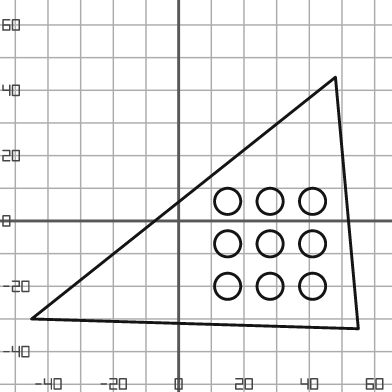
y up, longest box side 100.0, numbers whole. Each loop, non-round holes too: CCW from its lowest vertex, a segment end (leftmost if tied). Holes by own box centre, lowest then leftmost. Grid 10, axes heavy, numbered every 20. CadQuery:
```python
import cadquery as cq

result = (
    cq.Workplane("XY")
    .moveTo(55.0, -33.0)
    .lineTo(48.0, 44.0)
    .lineTo(-45.0, -30.0)
    .close()
    .moveTo(15.0, -20.0)
    .circle(4.0)
    .moveTo(28.0, -20.0)
    .circle(4.0)
    .moveTo(41.0, -20.0)
    .circle(4.0)
    .moveTo(15.0, -7.0)
    .circle(4.0)
    .moveTo(28.0, -7.0)
    .circle(4.0)
    .moveTo(41.0, -7.0)
    .circle(4.0)
    .moveTo(15.0, 6.0)
    .circle(4.0)
    .moveTo(28.0, 6.0)
    .circle(4.0)
    .moveTo(41.0, 6.0)
    .circle(4.0)
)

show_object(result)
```